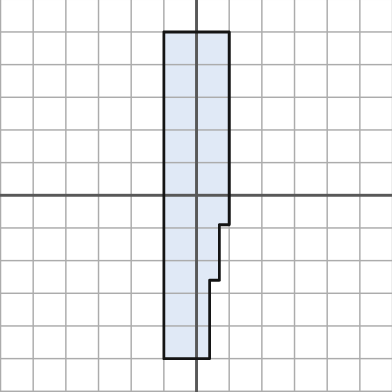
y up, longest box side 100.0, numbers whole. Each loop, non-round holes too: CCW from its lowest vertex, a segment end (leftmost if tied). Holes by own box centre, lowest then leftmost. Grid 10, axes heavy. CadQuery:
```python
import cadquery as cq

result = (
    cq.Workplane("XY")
    .moveTo(-10.0, -50.0)
    .lineTo(4.0, -50.0)
    .lineTo(4.0, -26.0)
    .lineTo(7.0, -26.0)
    .lineTo(7.0, -9.0)
    .lineTo(10.0, -9.0)
    .lineTo(10.0, 50.0)
    .lineTo(-10.0, 50.0)
    .close()
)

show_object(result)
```